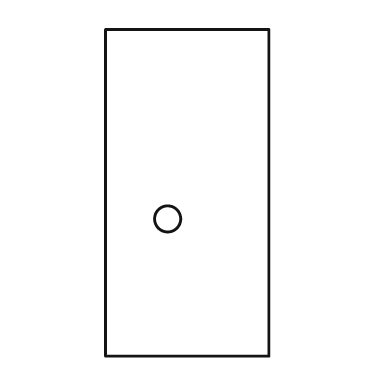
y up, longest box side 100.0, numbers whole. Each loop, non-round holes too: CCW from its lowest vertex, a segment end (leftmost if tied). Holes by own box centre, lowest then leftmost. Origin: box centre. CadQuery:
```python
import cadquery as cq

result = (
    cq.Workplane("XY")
    .moveTo(-25.0, -50.0)
    .lineTo(25.0, -50.0)
    .lineTo(25.0, 50.0)
    .lineTo(-25.0, 50.0)
    .close()
    .moveTo(-6.0, -8.0)
    .circle(4.0)
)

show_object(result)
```